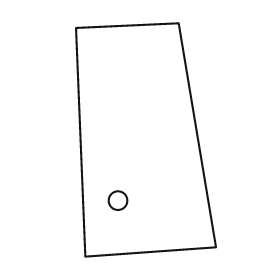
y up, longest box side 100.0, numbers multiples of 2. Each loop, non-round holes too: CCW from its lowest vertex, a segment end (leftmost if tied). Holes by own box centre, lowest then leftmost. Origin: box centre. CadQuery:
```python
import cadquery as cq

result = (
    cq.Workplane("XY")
    .moveTo(-26.0, -50.0)
    .lineTo(30.0, -46.0)
    .lineTo(14.0, 50.0)
    .lineTo(-30.0, 48.0)
    .close()
    .moveTo(-12.0, -26.0)
    .circle(4.0)
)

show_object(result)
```